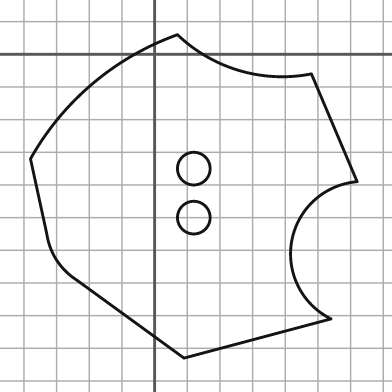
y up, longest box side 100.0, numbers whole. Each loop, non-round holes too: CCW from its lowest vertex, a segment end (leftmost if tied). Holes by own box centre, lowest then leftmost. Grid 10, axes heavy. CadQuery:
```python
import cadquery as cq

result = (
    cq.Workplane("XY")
    .moveTo(9.0, -93.0)
    .lineTo(54.0, -81.0)
    .threePointArc((42.0, -57.0), (62.0, -39.0))
    .lineTo(48.0, -6.0)
    .threePointArc((26.0, -5.0), (7.0, 6.0))
    .threePointArc((-19.0, -9.0), (-38.0, -32.0))
    .lineTo(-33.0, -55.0)
    .threePointArc((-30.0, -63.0), (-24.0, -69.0))
    .close()
    .moveTo(12.0, -50.0)
    .circle(5.0)
    .moveTo(12.0, -35.0)
    .circle(5.0)
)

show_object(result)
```